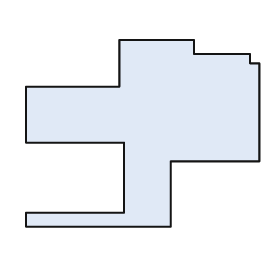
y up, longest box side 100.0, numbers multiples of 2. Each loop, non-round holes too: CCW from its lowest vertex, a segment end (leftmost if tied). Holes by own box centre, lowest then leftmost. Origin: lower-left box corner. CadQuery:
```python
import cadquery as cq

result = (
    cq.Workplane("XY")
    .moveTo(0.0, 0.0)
    .lineTo(62.0, 0.0)
    .lineTo(62.0, 28.0)
    .lineTo(100.0, 28.0)
    .lineTo(100.0, 70.0)
    .lineTo(96.0, 70.0)
    .lineTo(96.0, 74.0)
    .lineTo(72.0, 74.0)
    .lineTo(72.0, 80.0)
    .lineTo(40.0, 80.0)
    .lineTo(40.0, 60.0)
    .lineTo(0.0, 60.0)
    .lineTo(0.0, 36.0)
    .lineTo(42.0, 36.0)
    .lineTo(42.0, 6.0)
    .lineTo(0.0, 6.0)
    .close()
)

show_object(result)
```